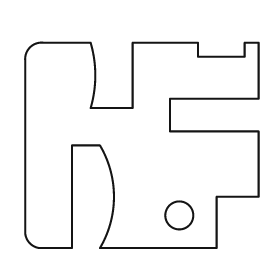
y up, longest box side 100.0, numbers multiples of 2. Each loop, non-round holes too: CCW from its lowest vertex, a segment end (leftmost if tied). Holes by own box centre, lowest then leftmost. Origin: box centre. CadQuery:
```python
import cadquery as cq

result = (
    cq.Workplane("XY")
    .moveTo(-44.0, -44.0)
    .lineTo(-30.0, -44.0)
    .lineTo(-30.0, 0.0)
    .lineTo(-18.0, 0.0)
    .threePointArc((-12.0, -22.0), (-18.0, -44.0))
    .lineTo(32.0, -44.0)
    .lineTo(32.0, -22.0)
    .lineTo(50.0, -22.0)
    .lineTo(50.0, 6.0)
    .lineTo(12.0, 6.0)
    .lineTo(12.0, 20.0)
    .lineTo(50.0, 20.0)
    .lineTo(50.0, 44.0)
    .lineTo(44.0, 44.0)
    .lineTo(44.0, 38.0)
    .lineTo(24.0, 38.0)
    .lineTo(24.0, 44.0)
    .lineTo(-4.0, 44.0)
    .lineTo(-4.0, 16.0)
    .lineTo(-22.0, 16.0)
    .threePointArc((-20.0, 30.0), (-22.0, 44.0))
    .lineTo(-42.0, 44.0)
    .threePointArc((-48.0, 42.0), (-50.0, 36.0))
    .lineTo(-50.0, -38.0)
    .threePointArc((-48.0, -42.0), (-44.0, -44.0))
    .close()
    .moveTo(16.0, -30.0)
    .circle(6.0)
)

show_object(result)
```